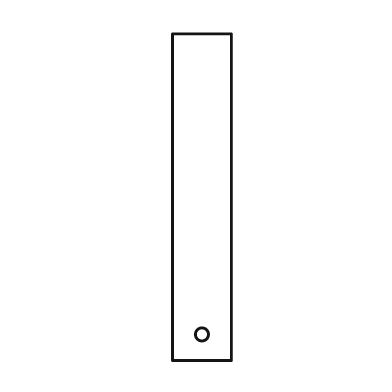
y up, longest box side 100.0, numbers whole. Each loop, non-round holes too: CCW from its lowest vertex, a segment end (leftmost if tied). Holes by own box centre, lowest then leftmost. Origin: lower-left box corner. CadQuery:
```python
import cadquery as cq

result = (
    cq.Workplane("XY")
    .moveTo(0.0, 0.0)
    .lineTo(18.0, 0.0)
    .lineTo(18.0, 100.0)
    .lineTo(0.0, 100.0)
    .close()
    .moveTo(9.0, 8.0)
    .circle(2.0)
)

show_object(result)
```